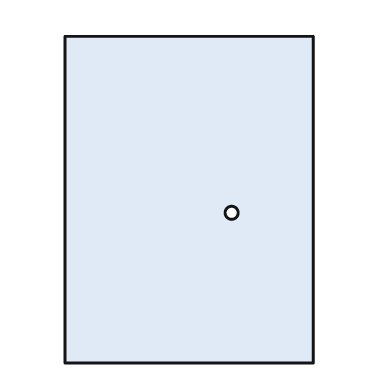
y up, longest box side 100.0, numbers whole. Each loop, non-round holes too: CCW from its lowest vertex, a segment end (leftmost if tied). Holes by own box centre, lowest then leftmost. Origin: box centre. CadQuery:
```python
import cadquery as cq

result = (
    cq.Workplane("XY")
    .moveTo(-38.0, -50.0)
    .lineTo(38.0, -50.0)
    .lineTo(38.0, 50.0)
    .lineTo(-38.0, 50.0)
    .close()
    .moveTo(13.0, -4.0)
    .circle(2.0)
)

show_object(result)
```